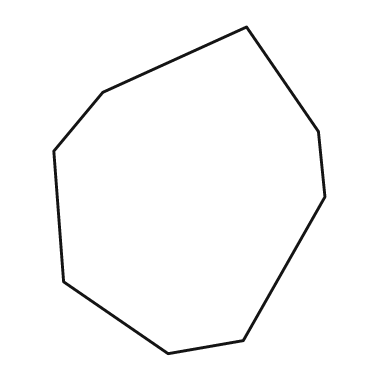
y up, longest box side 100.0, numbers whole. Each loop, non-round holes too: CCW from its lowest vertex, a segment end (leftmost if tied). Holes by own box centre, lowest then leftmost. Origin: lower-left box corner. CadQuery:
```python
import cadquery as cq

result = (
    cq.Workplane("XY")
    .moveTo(35.0, 0.0)
    .lineTo(58.0, 4.0)
    .lineTo(83.0, 48.0)
    .lineTo(81.0, 68.0)
    .lineTo(59.0, 100.0)
    .lineTo(15.0, 80.0)
    .lineTo(0.0, 62.0)
    .lineTo(3.0, 22.0)
    .close()
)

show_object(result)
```